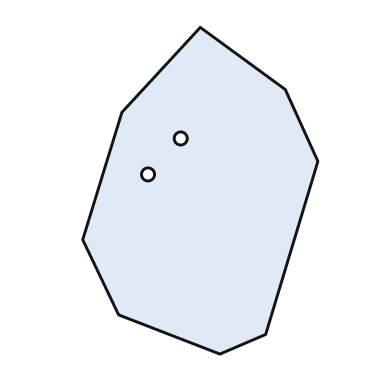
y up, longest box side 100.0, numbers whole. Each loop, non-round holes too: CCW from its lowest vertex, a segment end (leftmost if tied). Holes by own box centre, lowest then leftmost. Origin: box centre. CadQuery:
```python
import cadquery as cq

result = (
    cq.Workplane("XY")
    .moveTo(6.0, -50.0)
    .lineTo(20.0, -44.0)
    .lineTo(36.0, 9.0)
    .lineTo(26.0, 31.0)
    .lineTo(0.0, 50.0)
    .lineTo(-24.0, 24.0)
    .lineTo(-36.0, -15.0)
    .lineTo(-25.0, -38.0)
    .close()
    .moveTo(-16.0, 5.0)
    .circle(2.0)
    .moveTo(-6.0, 16.0)
    .circle(2.0)
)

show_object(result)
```